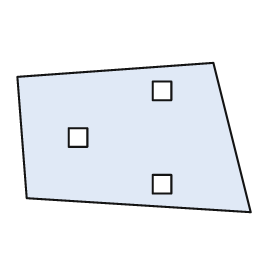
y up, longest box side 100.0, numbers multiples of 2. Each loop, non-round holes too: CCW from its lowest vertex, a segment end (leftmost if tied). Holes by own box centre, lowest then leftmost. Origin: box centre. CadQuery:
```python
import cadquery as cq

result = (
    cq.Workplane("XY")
    .moveTo(50.0, -32.0)
    .lineTo(34.0, 32.0)
    .lineTo(-50.0, 26.0)
    .lineTo(-46.0, -26.0)
    .close()
    .moveTo(8.0, -24.0)
    .lineTo(16.0, -24.0)
    .lineTo(16.0, -16.0)
    .lineTo(8.0, -16.0)
    .close()
    .moveTo(-28.0, -4.0)
    .lineTo(-20.0, -4.0)
    .lineTo(-20.0, 4.0)
    .lineTo(-28.0, 4.0)
    .close()
    .moveTo(8.0, 16.0)
    .lineTo(16.0, 16.0)
    .lineTo(16.0, 24.0)
    .lineTo(8.0, 24.0)
    .close()
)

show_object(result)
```